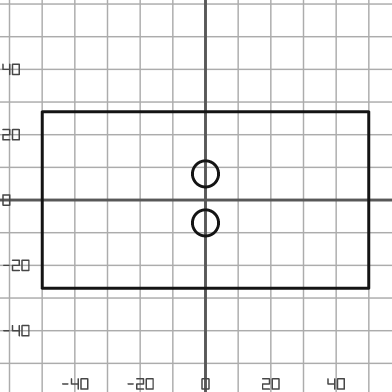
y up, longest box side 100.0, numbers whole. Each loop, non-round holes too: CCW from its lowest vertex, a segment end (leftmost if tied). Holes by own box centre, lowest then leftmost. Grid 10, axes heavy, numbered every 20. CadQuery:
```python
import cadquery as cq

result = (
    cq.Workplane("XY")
    .moveTo(-50.0, -27.0)
    .lineTo(50.0, -27.0)
    .lineTo(50.0, 27.0)
    .lineTo(-50.0, 27.0)
    .close()
    .moveTo(0.0, -7.0)
    .circle(4.0)
    .moveTo(0.0, 8.0)
    .circle(4.0)
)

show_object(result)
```